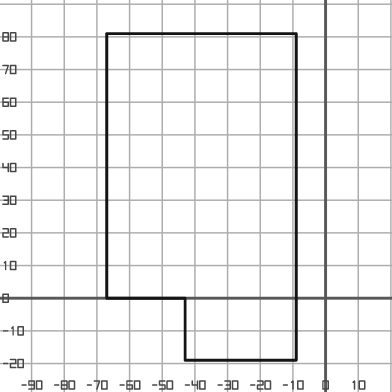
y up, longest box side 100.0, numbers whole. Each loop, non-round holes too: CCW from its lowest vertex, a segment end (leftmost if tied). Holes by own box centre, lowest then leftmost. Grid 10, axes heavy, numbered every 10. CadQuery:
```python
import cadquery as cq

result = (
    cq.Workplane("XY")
    .moveTo(-43.0, -19.0)
    .lineTo(-9.0, -19.0)
    .lineTo(-9.0, 81.0)
    .lineTo(-67.0, 81.0)
    .lineTo(-67.0, 0.0)
    .lineTo(-43.0, 0.0)
    .close()
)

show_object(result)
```